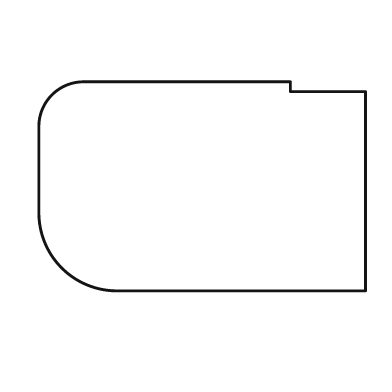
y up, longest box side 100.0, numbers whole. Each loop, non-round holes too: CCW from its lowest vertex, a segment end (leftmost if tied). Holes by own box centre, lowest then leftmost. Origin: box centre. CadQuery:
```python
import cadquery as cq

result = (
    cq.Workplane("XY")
    .moveTo(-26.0, -32.0)
    .lineTo(50.0, -32.0)
    .lineTo(50.0, 29.0)
    .lineTo(27.0, 29.0)
    .lineTo(27.0, 32.0)
    .lineTo(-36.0, 32.0)
    .threePointArc((-46.0, 28.0), (-50.0, 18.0))
    .lineTo(-50.0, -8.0)
    .threePointArc((-43.0, -25.0), (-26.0, -32.0))
    .close()
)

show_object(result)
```